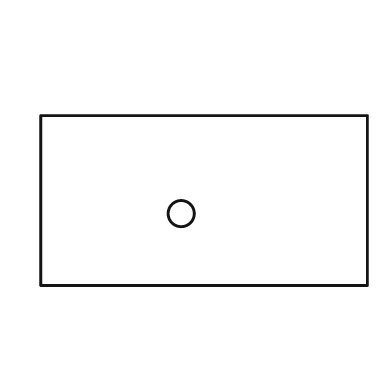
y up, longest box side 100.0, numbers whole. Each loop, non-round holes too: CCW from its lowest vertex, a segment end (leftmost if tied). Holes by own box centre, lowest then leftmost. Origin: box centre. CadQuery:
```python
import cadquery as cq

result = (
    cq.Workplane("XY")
    .moveTo(-50.0, -26.0)
    .lineTo(50.0, -26.0)
    .lineTo(50.0, 26.0)
    .lineTo(-50.0, 26.0)
    .close()
    .moveTo(-7.0, -4.0)
    .circle(4.0)
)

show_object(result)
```